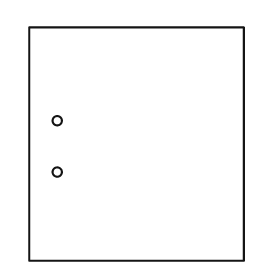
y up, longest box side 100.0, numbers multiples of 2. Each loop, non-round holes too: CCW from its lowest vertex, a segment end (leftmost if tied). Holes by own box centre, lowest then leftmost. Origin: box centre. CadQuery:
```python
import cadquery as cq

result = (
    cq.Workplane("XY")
    .moveTo(-46.0, -50.0)
    .lineTo(46.0, -50.0)
    .lineTo(46.0, 50.0)
    .lineTo(-46.0, 50.0)
    .close()
    .moveTo(-34.0, -12.0)
    .circle(2.0)
    .moveTo(-34.0, 10.0)
    .circle(2.0)
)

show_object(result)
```